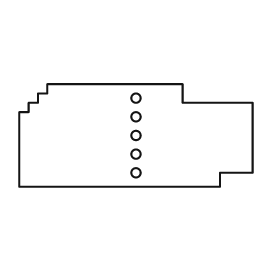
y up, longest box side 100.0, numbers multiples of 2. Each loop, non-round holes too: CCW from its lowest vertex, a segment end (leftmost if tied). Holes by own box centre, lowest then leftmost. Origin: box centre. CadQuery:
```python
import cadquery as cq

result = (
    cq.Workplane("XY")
    .moveTo(-50.0, -22.0)
    .lineTo(36.0, -22.0)
    .lineTo(36.0, -16.0)
    .lineTo(50.0, -16.0)
    .lineTo(50.0, 14.0)
    .lineTo(20.0, 14.0)
    .lineTo(20.0, 22.0)
    .lineTo(-38.0, 22.0)
    .lineTo(-38.0, 18.0)
    .lineTo(-42.0, 18.0)
    .lineTo(-42.0, 14.0)
    .lineTo(-46.0, 14.0)
    .lineTo(-46.0, 10.0)
    .lineTo(-50.0, 10.0)
    .close()
    .moveTo(0.0, -16.0)
    .circle(2.0)
    .moveTo(0.0, -8.0)
    .circle(2.0)
    .moveTo(0.0, 0.0)
    .circle(2.0)
    .moveTo(0.0, 8.0)
    .circle(2.0)
    .moveTo(0.0, 16.0)
    .circle(2.0)
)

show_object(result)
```